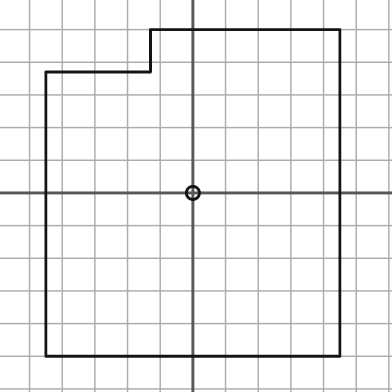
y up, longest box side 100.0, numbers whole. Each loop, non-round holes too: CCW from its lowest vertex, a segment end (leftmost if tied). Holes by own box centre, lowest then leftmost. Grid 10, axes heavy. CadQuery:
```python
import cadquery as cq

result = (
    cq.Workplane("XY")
    .moveTo(-45.0, -50.0)
    .lineTo(45.0, -50.0)
    .lineTo(45.0, 50.0)
    .lineTo(-13.0, 50.0)
    .lineTo(-13.0, 37.0)
    .lineTo(-45.0, 37.0)
    .close()
    .moveTo(0.0, 0.0)
    .circle(2.0)
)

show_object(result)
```